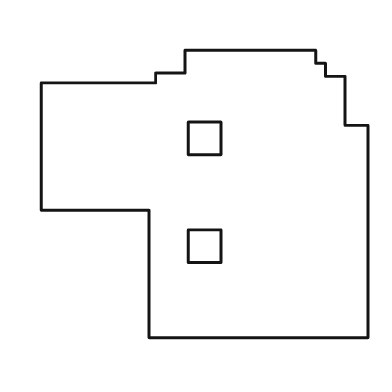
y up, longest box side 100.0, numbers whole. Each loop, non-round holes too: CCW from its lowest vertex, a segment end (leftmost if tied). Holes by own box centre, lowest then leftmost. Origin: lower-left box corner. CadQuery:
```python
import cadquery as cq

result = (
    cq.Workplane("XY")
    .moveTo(33.0, 0.0)
    .lineTo(100.0, 0.0)
    .lineTo(100.0, 65.0)
    .lineTo(93.0, 65.0)
    .lineTo(93.0, 80.0)
    .lineTo(87.0, 80.0)
    .lineTo(87.0, 84.0)
    .lineTo(84.0, 84.0)
    .lineTo(84.0, 88.0)
    .lineTo(44.0, 88.0)
    .lineTo(44.0, 81.0)
    .lineTo(35.0, 81.0)
    .lineTo(35.0, 78.0)
    .lineTo(0.0, 78.0)
    .lineTo(0.0, 39.0)
    .lineTo(33.0, 39.0)
    .close()
    .moveTo(45.0, 23.0)
    .lineTo(55.0, 23.0)
    .lineTo(55.0, 33.0)
    .lineTo(45.0, 33.0)
    .close()
    .moveTo(45.0, 56.0)
    .lineTo(55.0, 56.0)
    .lineTo(55.0, 66.0)
    .lineTo(45.0, 66.0)
    .close()
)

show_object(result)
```